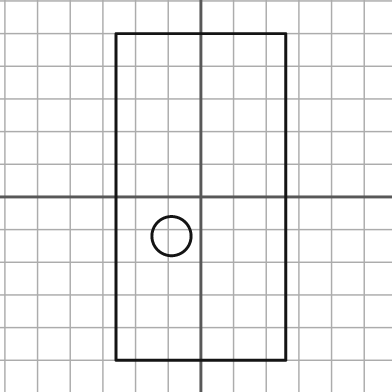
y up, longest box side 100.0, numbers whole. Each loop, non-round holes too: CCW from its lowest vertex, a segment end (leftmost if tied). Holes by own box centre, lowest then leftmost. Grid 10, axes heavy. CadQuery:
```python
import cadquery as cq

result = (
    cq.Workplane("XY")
    .moveTo(-26.0, -50.0)
    .lineTo(26.0, -50.0)
    .lineTo(26.0, 50.0)
    .lineTo(-26.0, 50.0)
    .close()
    .moveTo(-9.0, -12.0)
    .circle(6.0)
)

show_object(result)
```